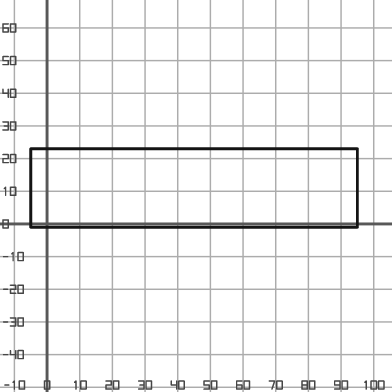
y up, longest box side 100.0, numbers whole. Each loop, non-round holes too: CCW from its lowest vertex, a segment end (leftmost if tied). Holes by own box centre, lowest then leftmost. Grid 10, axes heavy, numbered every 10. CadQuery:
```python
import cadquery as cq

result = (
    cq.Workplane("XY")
    .moveTo(-5.0, -1.0)
    .lineTo(95.0, -1.0)
    .lineTo(95.0, 23.0)
    .lineTo(-5.0, 23.0)
    .close()
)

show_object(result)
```